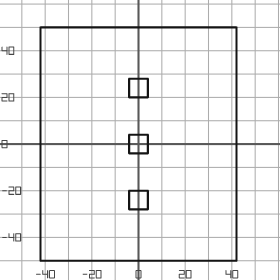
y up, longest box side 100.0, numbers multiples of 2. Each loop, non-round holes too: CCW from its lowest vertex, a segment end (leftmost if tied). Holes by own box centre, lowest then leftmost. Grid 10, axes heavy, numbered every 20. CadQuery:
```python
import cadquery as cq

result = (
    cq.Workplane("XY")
    .moveTo(-42.0, -50.0)
    .lineTo(42.0, -50.0)
    .lineTo(42.0, 50.0)
    .lineTo(-42.0, 50.0)
    .close()
    .moveTo(-4.0, -28.0)
    .lineTo(4.0, -28.0)
    .lineTo(4.0, -20.0)
    .lineTo(-4.0, -20.0)
    .close()
    .moveTo(-4.0, -4.0)
    .lineTo(4.0, -4.0)
    .lineTo(4.0, 4.0)
    .lineTo(-4.0, 4.0)
    .close()
    .moveTo(-4.0, 20.0)
    .lineTo(4.0, 20.0)
    .lineTo(4.0, 28.0)
    .lineTo(-4.0, 28.0)
    .close()
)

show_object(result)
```